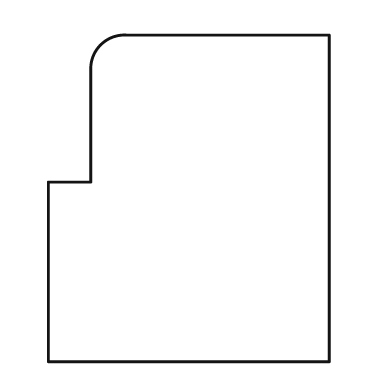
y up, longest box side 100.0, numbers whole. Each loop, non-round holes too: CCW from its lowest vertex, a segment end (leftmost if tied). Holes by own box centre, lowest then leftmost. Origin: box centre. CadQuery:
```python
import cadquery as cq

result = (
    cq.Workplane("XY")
    .moveTo(-43.0, -50.0)
    .lineTo(43.0, -50.0)
    .lineTo(43.0, 50.0)
    .lineTo(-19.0, 50.0)
    .threePointArc((-27.0, 47.0), (-30.0, 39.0))
    .lineTo(-30.0, 5.0)
    .lineTo(-43.0, 5.0)
    .close()
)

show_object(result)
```